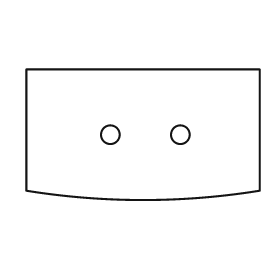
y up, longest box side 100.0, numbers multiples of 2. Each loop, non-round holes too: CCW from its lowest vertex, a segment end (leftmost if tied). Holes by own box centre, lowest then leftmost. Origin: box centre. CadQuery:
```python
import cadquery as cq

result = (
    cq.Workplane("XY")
    .moveTo(-50.0, -24.0)
    .threePointArc((0.0, -28.0), (50.0, -24.0))
    .lineTo(50.0, 28.0)
    .lineTo(-50.0, 28.0)
    .close()
    .moveTo(-14.0, 0.0)
    .circle(4.0)
    .moveTo(16.0, 0.0)
    .circle(4.0)
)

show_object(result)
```